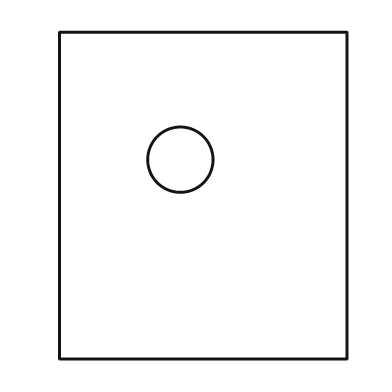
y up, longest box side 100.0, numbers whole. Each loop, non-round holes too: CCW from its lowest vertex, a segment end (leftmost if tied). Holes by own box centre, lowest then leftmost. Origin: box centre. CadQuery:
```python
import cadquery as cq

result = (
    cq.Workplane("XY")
    .moveTo(-44.0, -50.0)
    .lineTo(44.0, -50.0)
    .lineTo(44.0, 50.0)
    .lineTo(-44.0, 50.0)
    .close()
    .moveTo(-7.0, 11.0)
    .circle(10.0)
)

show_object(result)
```